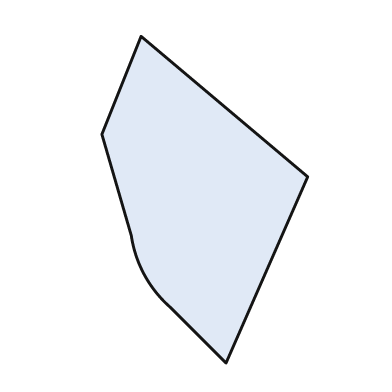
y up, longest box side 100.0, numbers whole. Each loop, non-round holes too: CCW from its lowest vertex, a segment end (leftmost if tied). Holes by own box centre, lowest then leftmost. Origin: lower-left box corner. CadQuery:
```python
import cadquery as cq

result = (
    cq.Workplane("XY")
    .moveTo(38.0, 0.0)
    .lineTo(63.0, 57.0)
    .lineTo(12.0, 100.0)
    .lineTo(0.0, 70.0)
    .lineTo(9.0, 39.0)
    .threePointArc((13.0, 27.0), (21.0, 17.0))
    .close()
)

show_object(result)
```